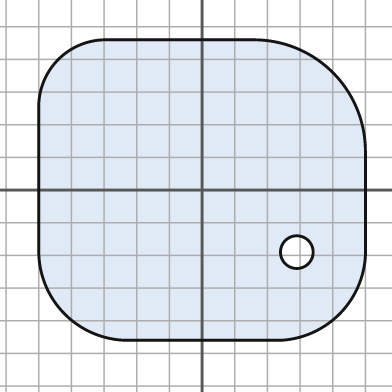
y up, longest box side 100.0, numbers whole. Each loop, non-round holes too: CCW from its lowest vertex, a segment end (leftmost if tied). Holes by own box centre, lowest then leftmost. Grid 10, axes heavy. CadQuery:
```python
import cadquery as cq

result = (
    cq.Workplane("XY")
    .moveTo(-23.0, -46.0)
    .lineTo(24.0, -46.0)
    .threePointArc((42.0, -38.0), (50.0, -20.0))
    .lineTo(50.0, 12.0)
    .threePointArc((40.0, 36.0), (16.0, 46.0))
    .lineTo(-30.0, 46.0)
    .threePointArc((-44.0, 40.0), (-50.0, 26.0))
    .lineTo(-50.0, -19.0)
    .threePointArc((-42.0, -38.0), (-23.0, -46.0))
    .close()
    .moveTo(29.0, -19.0)
    .circle(5.0)
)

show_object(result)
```